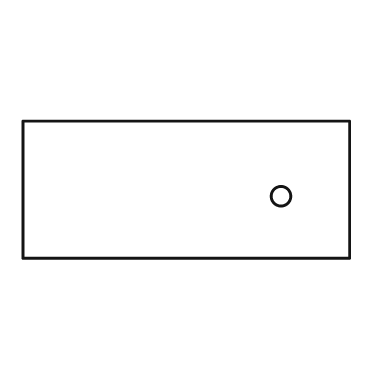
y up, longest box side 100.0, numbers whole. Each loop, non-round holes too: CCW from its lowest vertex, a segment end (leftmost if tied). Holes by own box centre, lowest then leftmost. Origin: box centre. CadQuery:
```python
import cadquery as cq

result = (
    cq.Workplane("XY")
    .moveTo(-50.0, -21.0)
    .lineTo(50.0, -21.0)
    .lineTo(50.0, 21.0)
    .lineTo(-50.0, 21.0)
    .close()
    .moveTo(29.0, -2.0)
    .circle(3.0)
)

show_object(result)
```